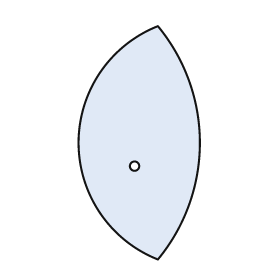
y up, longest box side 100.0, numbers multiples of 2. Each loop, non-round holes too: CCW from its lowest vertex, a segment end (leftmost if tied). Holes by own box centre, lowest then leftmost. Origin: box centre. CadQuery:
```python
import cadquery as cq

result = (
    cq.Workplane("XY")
    .moveTo(8.0, -50.0)
    .threePointArc((26.0, 0.0), (8.0, 50.0))
    .threePointArc((-26.0, 0.0), (8.0, -50.0))
    .close()
    .moveTo(-2.0, -10.0)
    .circle(2.0)
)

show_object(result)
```